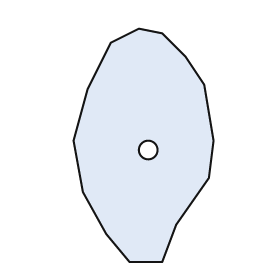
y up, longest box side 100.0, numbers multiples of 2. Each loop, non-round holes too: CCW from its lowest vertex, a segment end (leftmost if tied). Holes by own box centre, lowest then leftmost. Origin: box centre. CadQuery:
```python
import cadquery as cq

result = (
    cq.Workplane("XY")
    .moveTo(-6.0, -50.0)
    .lineTo(8.0, -50.0)
    .lineTo(14.0, -34.0)
    .lineTo(28.0, -14.0)
    .lineTo(30.0, 2.0)
    .lineTo(26.0, 26.0)
    .lineTo(18.0, 38.0)
    .lineTo(8.0, 48.0)
    .lineTo(-2.0, 50.0)
    .lineTo(-14.0, 44.0)
    .lineTo(-24.0, 24.0)
    .lineTo(-30.0, 2.0)
    .lineTo(-26.0, -20.0)
    .lineTo(-16.0, -38.0)
    .close()
    .moveTo(2.0, -2.0)
    .circle(4.0)
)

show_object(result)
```